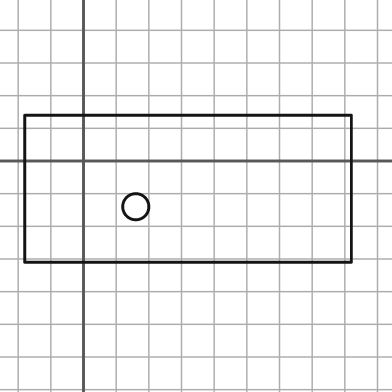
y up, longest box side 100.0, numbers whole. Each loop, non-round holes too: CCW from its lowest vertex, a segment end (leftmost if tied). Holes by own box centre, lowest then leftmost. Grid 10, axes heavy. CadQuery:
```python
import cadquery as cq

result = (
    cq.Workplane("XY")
    .moveTo(-18.0, -31.0)
    .lineTo(82.0, -31.0)
    .lineTo(82.0, 14.0)
    .lineTo(-18.0, 14.0)
    .close()
    .moveTo(16.0, -14.0)
    .circle(4.0)
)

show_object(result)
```